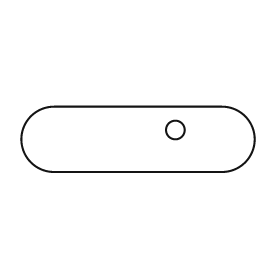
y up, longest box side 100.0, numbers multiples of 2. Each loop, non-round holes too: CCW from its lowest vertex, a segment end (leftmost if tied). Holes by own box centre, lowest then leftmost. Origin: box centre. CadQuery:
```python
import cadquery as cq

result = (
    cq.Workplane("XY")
    .moveTo(-36.0, -14.0)
    .lineTo(36.0, -14.0)
    .threePointArc((50.0, 0.0), (36.0, 14.0))
    .lineTo(-36.0, 14.0)
    .threePointArc((-50.0, 0.0), (-36.0, -14.0))
    .close()
    .moveTo(16.0, 4.0)
    .circle(4.0)
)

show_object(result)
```